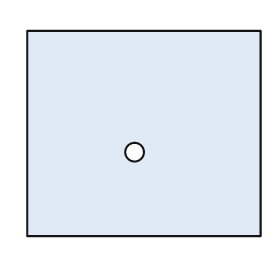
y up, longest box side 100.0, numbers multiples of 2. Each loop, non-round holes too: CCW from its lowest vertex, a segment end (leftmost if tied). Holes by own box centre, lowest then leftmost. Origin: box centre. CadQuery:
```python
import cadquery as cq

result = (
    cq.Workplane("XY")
    .moveTo(-50.0, -44.0)
    .lineTo(50.0, -44.0)
    .lineTo(50.0, 44.0)
    .lineTo(-50.0, 44.0)
    .close()
    .moveTo(-4.0, -8.0)
    .circle(4.0)
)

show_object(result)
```